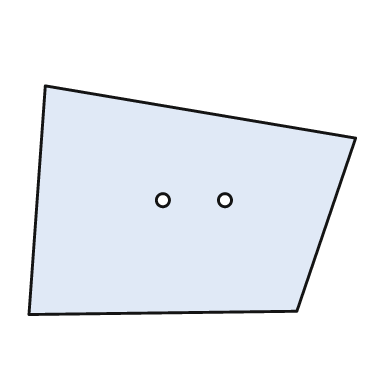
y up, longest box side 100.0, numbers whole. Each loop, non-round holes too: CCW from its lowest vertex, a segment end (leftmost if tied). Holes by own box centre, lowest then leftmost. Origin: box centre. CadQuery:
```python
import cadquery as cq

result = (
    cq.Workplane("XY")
    .moveTo(-50.0, -35.0)
    .lineTo(32.0, -34.0)
    .lineTo(50.0, 19.0)
    .lineTo(-45.0, 35.0)
    .close()
    .moveTo(-9.0, 0.0)
    .circle(2.0)
    .moveTo(10.0, 0.0)
    .circle(2.0)
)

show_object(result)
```